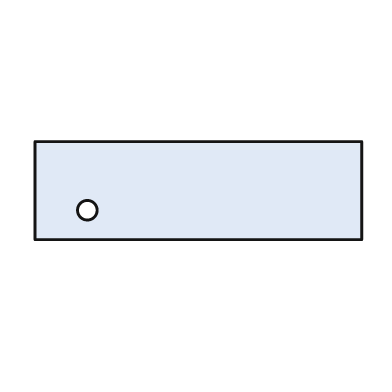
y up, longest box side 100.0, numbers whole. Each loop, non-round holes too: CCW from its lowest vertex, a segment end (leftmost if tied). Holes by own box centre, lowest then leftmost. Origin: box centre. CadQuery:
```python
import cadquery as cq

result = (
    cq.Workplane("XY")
    .moveTo(-50.0, -15.0)
    .lineTo(50.0, -15.0)
    .lineTo(50.0, 15.0)
    .lineTo(-50.0, 15.0)
    .close()
    .moveTo(-34.0, -6.0)
    .circle(3.0)
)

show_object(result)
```